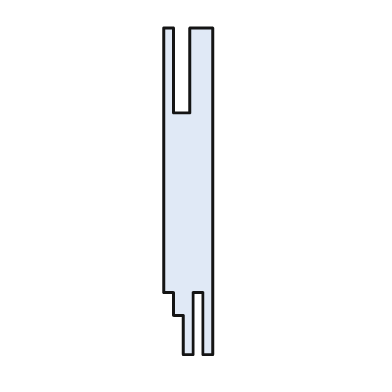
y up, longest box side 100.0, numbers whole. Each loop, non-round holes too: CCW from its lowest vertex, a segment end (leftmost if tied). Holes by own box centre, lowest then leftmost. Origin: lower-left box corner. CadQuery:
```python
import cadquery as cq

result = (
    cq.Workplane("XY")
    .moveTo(6.0, 0.0)
    .lineTo(9.0, 0.0)
    .lineTo(9.0, 19.0)
    .lineTo(12.0, 19.0)
    .lineTo(12.0, 0.0)
    .lineTo(15.0, 0.0)
    .lineTo(15.0, 100.0)
    .lineTo(8.0, 100.0)
    .lineTo(8.0, 74.0)
    .lineTo(3.0, 74.0)
    .lineTo(3.0, 100.0)
    .lineTo(0.0, 100.0)
    .lineTo(0.0, 19.0)
    .lineTo(3.0, 19.0)
    .lineTo(3.0, 12.0)
    .lineTo(6.0, 12.0)
    .close()
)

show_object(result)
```